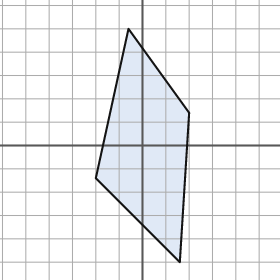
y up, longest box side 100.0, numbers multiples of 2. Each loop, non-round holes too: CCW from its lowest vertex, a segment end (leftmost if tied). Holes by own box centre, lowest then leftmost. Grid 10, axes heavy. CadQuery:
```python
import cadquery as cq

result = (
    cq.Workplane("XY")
    .moveTo(16.0, -50.0)
    .lineTo(20.0, 14.0)
    .lineTo(-6.0, 50.0)
    .lineTo(-20.0, -14.0)
    .close()
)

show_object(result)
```